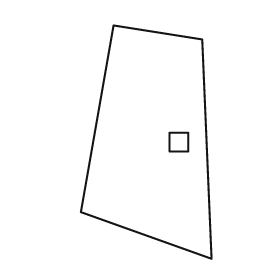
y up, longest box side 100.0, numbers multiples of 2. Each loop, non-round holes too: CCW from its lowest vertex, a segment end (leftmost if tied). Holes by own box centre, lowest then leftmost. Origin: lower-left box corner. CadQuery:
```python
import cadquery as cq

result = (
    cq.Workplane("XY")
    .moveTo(56.0, 0.0)
    .lineTo(52.0, 94.0)
    .lineTo(14.0, 100.0)
    .lineTo(0.0, 20.0)
    .close()
    .moveTo(38.0, 46.0)
    .lineTo(46.0, 46.0)
    .lineTo(46.0, 54.0)
    .lineTo(38.0, 54.0)
    .close()
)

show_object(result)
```